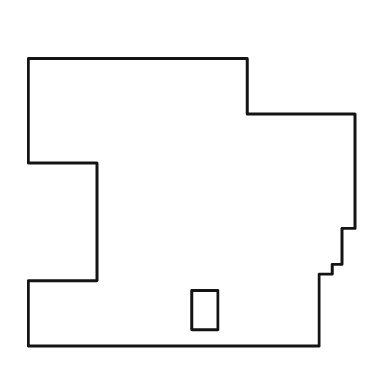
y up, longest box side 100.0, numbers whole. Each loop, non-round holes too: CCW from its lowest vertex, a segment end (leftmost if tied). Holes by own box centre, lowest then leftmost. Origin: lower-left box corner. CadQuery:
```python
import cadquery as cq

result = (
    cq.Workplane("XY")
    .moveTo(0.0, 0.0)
    .lineTo(89.0, 0.0)
    .lineTo(89.0, 22.0)
    .lineTo(93.0, 22.0)
    .lineTo(93.0, 25.0)
    .lineTo(96.0, 25.0)
    .lineTo(96.0, 36.0)
    .lineTo(100.0, 36.0)
    .lineTo(100.0, 71.0)
    .lineTo(67.0, 71.0)
    .lineTo(67.0, 88.0)
    .lineTo(0.0, 88.0)
    .lineTo(0.0, 56.0)
    .lineTo(21.0, 56.0)
    .lineTo(21.0, 20.0)
    .lineTo(0.0, 20.0)
    .close()
    .moveTo(50.0, 5.0)
    .lineTo(58.0, 5.0)
    .lineTo(58.0, 17.0)
    .lineTo(50.0, 17.0)
    .close()
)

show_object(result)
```